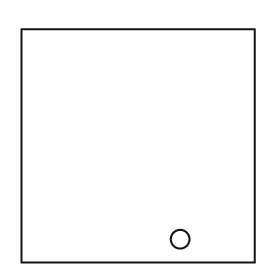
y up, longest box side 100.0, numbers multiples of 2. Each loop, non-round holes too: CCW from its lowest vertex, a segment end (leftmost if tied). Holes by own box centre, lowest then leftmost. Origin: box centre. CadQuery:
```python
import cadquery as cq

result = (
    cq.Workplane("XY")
    .moveTo(-50.0, -50.0)
    .lineTo(50.0, -50.0)
    .lineTo(50.0, 50.0)
    .lineTo(-50.0, 50.0)
    .close()
    .moveTo(18.0, -40.0)
    .circle(4.0)
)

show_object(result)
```